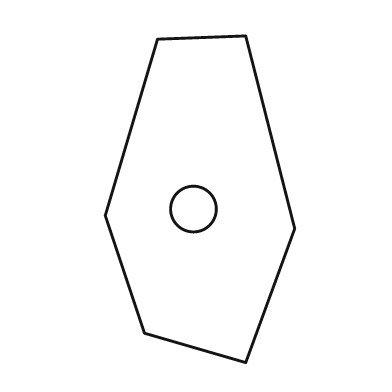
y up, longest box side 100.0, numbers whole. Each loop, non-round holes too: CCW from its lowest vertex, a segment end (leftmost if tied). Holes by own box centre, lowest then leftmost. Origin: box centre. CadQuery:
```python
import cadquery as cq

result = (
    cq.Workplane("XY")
    .moveTo(14.0, -50.0)
    .lineTo(29.0, -9.0)
    .lineTo(14.0, 50.0)
    .lineTo(-13.0, 49.0)
    .lineTo(-29.0, -5.0)
    .lineTo(-17.0, -41.0)
    .close()
    .moveTo(-2.0, -3.0)
    .circle(7.0)
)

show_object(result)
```